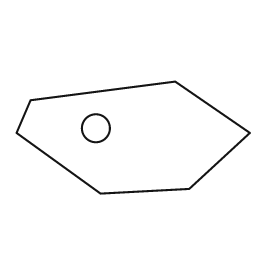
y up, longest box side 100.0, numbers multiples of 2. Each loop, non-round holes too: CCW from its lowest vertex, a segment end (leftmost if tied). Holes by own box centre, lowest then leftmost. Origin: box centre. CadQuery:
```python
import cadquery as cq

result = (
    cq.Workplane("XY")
    .moveTo(-14.0, -24.0)
    .lineTo(24.0, -22.0)
    .lineTo(50.0, 2.0)
    .lineTo(18.0, 24.0)
    .lineTo(-44.0, 16.0)
    .lineTo(-50.0, 2.0)
    .close()
    .moveTo(-16.0, 4.0)
    .circle(6.0)
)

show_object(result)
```